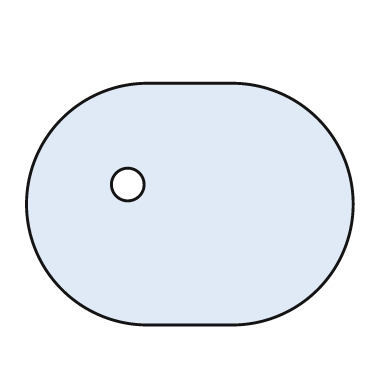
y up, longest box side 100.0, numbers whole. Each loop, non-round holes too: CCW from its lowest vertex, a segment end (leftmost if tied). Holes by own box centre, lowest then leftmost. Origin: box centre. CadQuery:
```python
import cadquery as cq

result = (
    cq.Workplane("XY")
    .moveTo(-13.0, -37.0)
    .lineTo(13.0, -37.0)
    .threePointArc((50.0, 0.0), (13.0, 37.0))
    .lineTo(-13.0, 37.0)
    .threePointArc((-50.0, 0.0), (-13.0, -37.0))
    .close()
    .moveTo(-19.0, 6.0)
    .circle(5.0)
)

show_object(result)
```